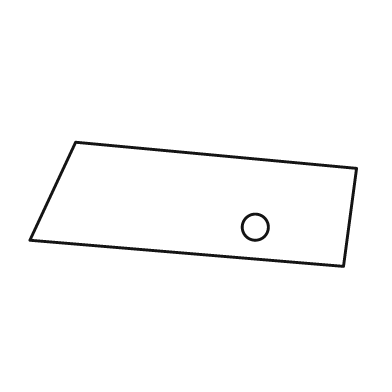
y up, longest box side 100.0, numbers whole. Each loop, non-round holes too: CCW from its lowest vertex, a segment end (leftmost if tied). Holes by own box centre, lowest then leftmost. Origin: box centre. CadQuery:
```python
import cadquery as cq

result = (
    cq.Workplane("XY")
    .moveTo(46.0, -19.0)
    .lineTo(50.0, 11.0)
    .lineTo(-36.0, 19.0)
    .lineTo(-50.0, -11.0)
    .close()
    .moveTo(19.0, -7.0)
    .circle(4.0)
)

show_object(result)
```